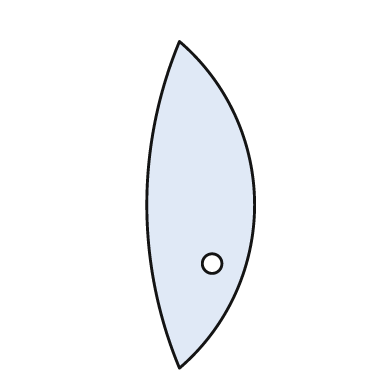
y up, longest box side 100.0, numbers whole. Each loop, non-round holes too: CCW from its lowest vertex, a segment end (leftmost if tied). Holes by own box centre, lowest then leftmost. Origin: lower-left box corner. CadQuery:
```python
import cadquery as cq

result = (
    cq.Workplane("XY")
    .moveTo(10.0, 0.0)
    .threePointArc((33.0, 50.0), (10.0, 100.0))
    .threePointArc((0.0, 50.0), (10.0, 0.0))
    .close()
    .moveTo(20.0, 32.0)
    .circle(3.0)
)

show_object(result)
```